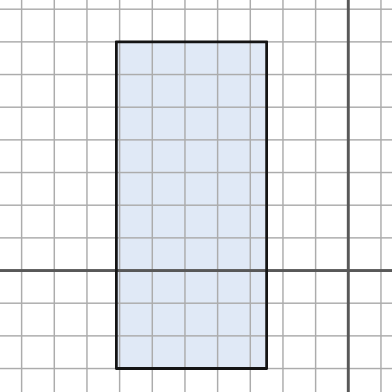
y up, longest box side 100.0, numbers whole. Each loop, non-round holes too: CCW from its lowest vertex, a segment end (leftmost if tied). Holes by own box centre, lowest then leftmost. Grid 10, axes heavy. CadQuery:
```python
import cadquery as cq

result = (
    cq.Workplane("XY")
    .moveTo(-71.0, -30.0)
    .lineTo(-25.0, -30.0)
    .lineTo(-25.0, 70.0)
    .lineTo(-71.0, 70.0)
    .close()
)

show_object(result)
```